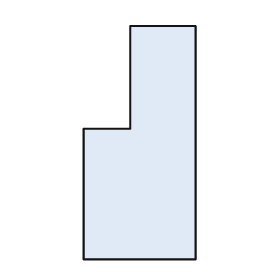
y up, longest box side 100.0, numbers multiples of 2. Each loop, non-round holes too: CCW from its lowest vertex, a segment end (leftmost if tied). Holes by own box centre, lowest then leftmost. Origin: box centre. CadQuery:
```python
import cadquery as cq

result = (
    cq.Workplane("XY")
    .moveTo(-24.0, -50.0)
    .lineTo(24.0, -50.0)
    .lineTo(24.0, 50.0)
    .lineTo(-4.0, 50.0)
    .lineTo(-4.0, 6.0)
    .lineTo(-24.0, 6.0)
    .close()
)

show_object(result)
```